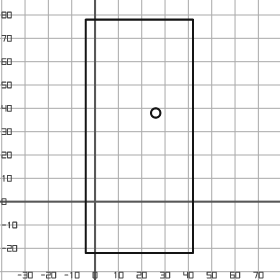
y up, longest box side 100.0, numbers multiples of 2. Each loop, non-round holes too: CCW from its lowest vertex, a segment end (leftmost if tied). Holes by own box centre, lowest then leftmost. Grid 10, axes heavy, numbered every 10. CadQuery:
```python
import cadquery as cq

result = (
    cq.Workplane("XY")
    .moveTo(-4.0, -22.0)
    .lineTo(42.0, -22.0)
    .lineTo(42.0, 78.0)
    .lineTo(-4.0, 78.0)
    .close()
    .moveTo(26.0, 38.0)
    .circle(2.0)
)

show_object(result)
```